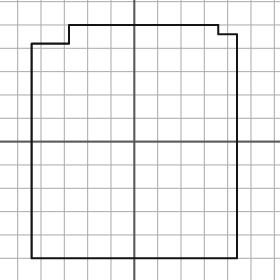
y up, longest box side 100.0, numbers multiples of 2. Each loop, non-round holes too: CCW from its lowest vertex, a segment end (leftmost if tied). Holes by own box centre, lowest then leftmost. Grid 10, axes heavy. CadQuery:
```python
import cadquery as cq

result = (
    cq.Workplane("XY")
    .moveTo(-44.0, -50.0)
    .lineTo(44.0, -50.0)
    .lineTo(44.0, 46.0)
    .lineTo(36.0, 46.0)
    .lineTo(36.0, 50.0)
    .lineTo(-28.0, 50.0)
    .lineTo(-28.0, 42.0)
    .lineTo(-44.0, 42.0)
    .close()
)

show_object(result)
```